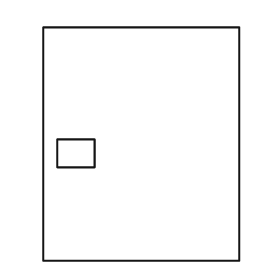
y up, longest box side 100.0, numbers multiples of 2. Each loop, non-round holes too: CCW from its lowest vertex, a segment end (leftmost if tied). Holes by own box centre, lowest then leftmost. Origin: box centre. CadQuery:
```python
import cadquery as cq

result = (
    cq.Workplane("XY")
    .moveTo(-42.0, -50.0)
    .lineTo(42.0, -50.0)
    .lineTo(42.0, 50.0)
    .lineTo(-42.0, 50.0)
    .close()
    .moveTo(-36.0, -10.0)
    .lineTo(-20.0, -10.0)
    .lineTo(-20.0, 2.0)
    .lineTo(-36.0, 2.0)
    .close()
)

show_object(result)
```